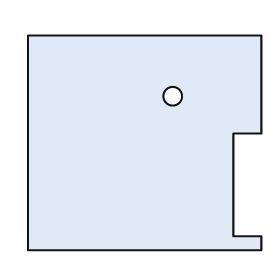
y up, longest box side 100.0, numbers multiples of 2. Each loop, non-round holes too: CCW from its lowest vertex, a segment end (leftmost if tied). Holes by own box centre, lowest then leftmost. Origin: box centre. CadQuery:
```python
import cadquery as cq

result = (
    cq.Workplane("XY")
    .moveTo(-50.0, -46.0)
    .lineTo(50.0, -46.0)
    .lineTo(50.0, -40.0)
    .lineTo(38.0, -40.0)
    .lineTo(38.0, 4.0)
    .lineTo(50.0, 4.0)
    .lineTo(50.0, 46.0)
    .lineTo(-50.0, 46.0)
    .close()
    .moveTo(12.0, 20.0)
    .circle(4.0)
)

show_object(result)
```